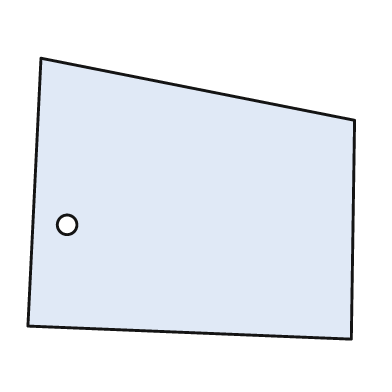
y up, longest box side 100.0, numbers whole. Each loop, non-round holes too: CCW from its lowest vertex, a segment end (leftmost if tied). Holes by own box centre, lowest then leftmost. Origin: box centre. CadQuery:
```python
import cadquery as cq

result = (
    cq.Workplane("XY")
    .moveTo(49.0, -43.0)
    .lineTo(50.0, 24.0)
    .lineTo(-46.0, 43.0)
    .lineTo(-50.0, -39.0)
    .close()
    .moveTo(-38.0, -8.0)
    .circle(3.0)
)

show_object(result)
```